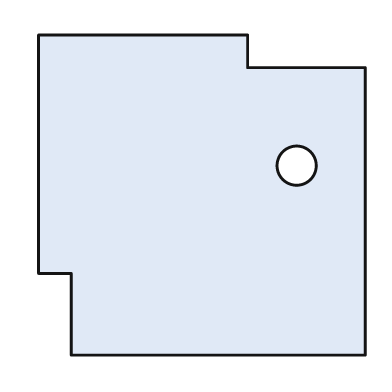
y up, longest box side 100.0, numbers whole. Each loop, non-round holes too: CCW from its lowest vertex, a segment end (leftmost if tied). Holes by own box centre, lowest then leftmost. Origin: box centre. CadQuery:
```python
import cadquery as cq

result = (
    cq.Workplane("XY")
    .moveTo(-40.0, -49.0)
    .lineTo(50.0, -49.0)
    .lineTo(50.0, 39.0)
    .lineTo(14.0, 39.0)
    .lineTo(14.0, 49.0)
    .lineTo(-50.0, 49.0)
    .lineTo(-50.0, -24.0)
    .lineTo(-40.0, -24.0)
    .close()
    .moveTo(29.0, 9.0)
    .circle(6.0)
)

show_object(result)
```